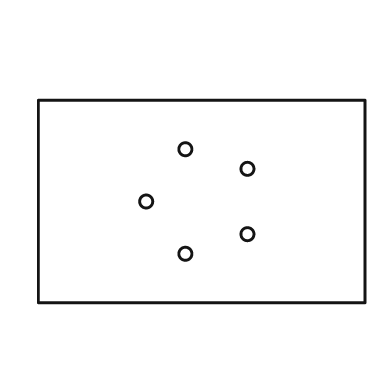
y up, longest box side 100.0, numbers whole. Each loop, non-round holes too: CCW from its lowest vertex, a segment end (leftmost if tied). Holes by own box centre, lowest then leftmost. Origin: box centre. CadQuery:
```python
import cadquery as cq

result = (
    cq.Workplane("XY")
    .moveTo(-50.0, -31.0)
    .lineTo(50.0, -31.0)
    .lineTo(50.0, 31.0)
    .lineTo(-50.0, 31.0)
    .close()
    .moveTo(-5.0, -16.0)
    .circle(2.0)
    .moveTo(14.0, -10.0)
    .circle(2.0)
    .moveTo(-17.0, 0.0)
    .circle(2.0)
    .moveTo(14.0, 10.0)
    .circle(2.0)
    .moveTo(-5.0, 16.0)
    .circle(2.0)
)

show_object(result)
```